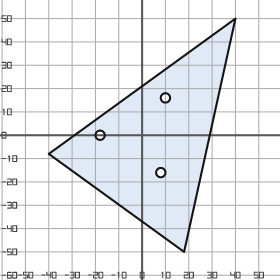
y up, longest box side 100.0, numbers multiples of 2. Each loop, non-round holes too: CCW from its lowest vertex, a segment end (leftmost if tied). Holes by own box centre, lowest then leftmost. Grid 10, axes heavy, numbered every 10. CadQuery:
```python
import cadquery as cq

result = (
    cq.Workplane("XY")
    .moveTo(18.0, -50.0)
    .lineTo(40.0, 50.0)
    .lineTo(-40.0, -8.0)
    .close()
    .moveTo(8.0, -16.0)
    .circle(2.0)
    .moveTo(-18.0, 0.0)
    .circle(2.0)
    .moveTo(10.0, 16.0)
    .circle(2.0)
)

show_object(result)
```